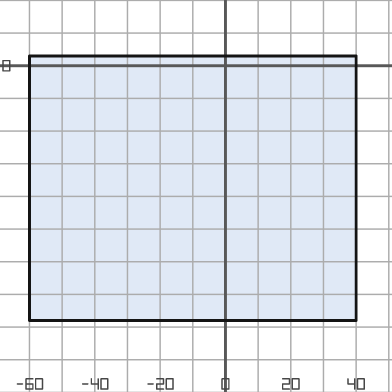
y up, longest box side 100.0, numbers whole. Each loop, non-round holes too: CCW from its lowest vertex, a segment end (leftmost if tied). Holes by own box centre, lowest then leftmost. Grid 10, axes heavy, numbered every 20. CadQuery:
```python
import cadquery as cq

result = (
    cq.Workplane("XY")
    .moveTo(-60.0, -78.0)
    .lineTo(40.0, -78.0)
    .lineTo(40.0, 3.0)
    .lineTo(-60.0, 3.0)
    .close()
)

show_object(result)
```